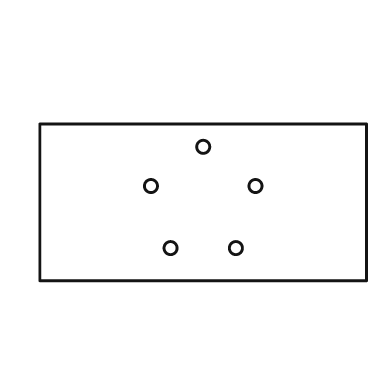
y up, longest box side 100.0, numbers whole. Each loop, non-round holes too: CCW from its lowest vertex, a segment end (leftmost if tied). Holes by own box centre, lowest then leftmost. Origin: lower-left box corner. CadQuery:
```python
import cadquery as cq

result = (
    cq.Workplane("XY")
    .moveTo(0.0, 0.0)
    .lineTo(100.0, 0.0)
    .lineTo(100.0, 48.0)
    .lineTo(0.0, 48.0)
    .close()
    .moveTo(40.0, 10.0)
    .circle(2.0)
    .moveTo(60.0, 10.0)
    .circle(2.0)
    .moveTo(34.0, 29.0)
    .circle(2.0)
    .moveTo(66.0, 29.0)
    .circle(2.0)
    .moveTo(50.0, 41.0)
    .circle(2.0)
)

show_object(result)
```